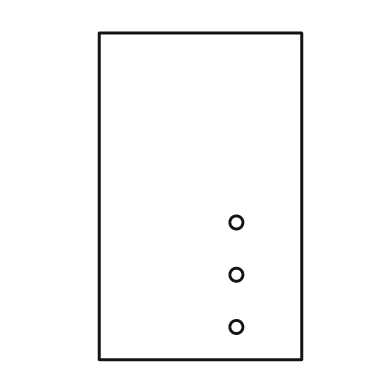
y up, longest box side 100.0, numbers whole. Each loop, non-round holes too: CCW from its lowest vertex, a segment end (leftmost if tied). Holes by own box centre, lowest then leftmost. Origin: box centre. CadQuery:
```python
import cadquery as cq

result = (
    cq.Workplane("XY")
    .moveTo(-31.0, -50.0)
    .lineTo(31.0, -50.0)
    .lineTo(31.0, 50.0)
    .lineTo(-31.0, 50.0)
    .close()
    .moveTo(11.0, -40.0)
    .circle(2.0)
    .moveTo(11.0, -24.0)
    .circle(2.0)
    .moveTo(11.0, -8.0)
    .circle(2.0)
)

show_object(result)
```